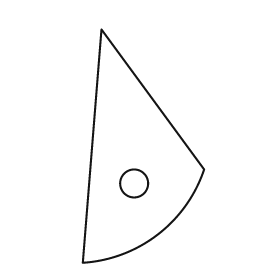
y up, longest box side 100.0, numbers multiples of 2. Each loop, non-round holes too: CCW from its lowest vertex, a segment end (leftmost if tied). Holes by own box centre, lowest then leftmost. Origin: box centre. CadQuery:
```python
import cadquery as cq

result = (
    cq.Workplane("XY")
    .moveTo(-26.0, -50.0)
    .threePointArc((6.0, -38.0), (26.0, -10.0))
    .lineTo(-18.0, 50.0)
    .close()
    .moveTo(-4.0, -16.0)
    .circle(6.0)
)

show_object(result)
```